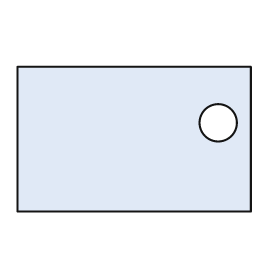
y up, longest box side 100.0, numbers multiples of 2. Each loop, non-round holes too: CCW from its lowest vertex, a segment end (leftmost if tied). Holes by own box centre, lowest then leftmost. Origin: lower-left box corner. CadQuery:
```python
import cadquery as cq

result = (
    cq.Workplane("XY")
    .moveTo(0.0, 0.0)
    .lineTo(100.0, 0.0)
    .lineTo(100.0, 62.0)
    .lineTo(0.0, 62.0)
    .close()
    .moveTo(86.0, 38.0)
    .circle(8.0)
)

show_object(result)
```